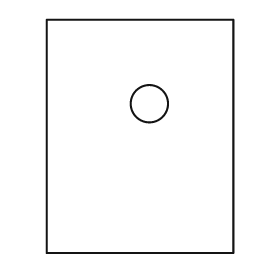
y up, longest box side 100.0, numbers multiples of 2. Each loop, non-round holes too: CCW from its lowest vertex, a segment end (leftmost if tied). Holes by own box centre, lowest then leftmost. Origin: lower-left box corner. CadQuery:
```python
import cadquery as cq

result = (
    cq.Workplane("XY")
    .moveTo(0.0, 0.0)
    .lineTo(80.0, 0.0)
    .lineTo(80.0, 100.0)
    .lineTo(0.0, 100.0)
    .close()
    .moveTo(44.0, 64.0)
    .circle(8.0)
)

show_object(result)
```